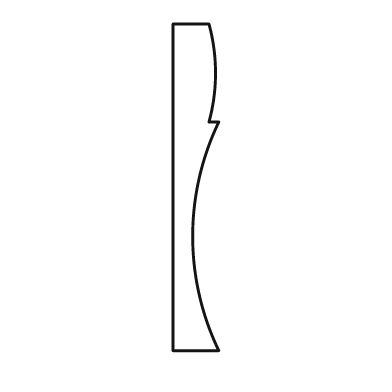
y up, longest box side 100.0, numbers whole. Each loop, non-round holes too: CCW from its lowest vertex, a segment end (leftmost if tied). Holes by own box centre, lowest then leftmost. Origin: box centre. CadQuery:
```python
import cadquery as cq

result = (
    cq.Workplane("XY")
    .moveTo(-7.0, -50.0)
    .lineTo(7.0, -50.0)
    .threePointArc((-1.0, -15.0), (7.0, 20.0))
    .lineTo(4.0, 20.0)
    .threePointArc((6.0, 35.0), (4.0, 50.0))
    .lineTo(-7.0, 50.0)
    .close()
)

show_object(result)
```